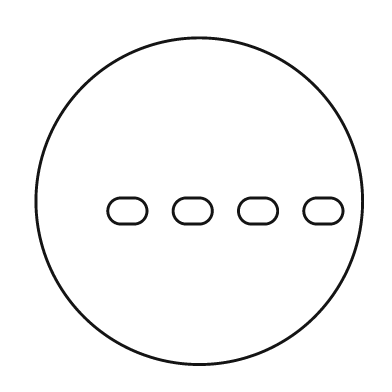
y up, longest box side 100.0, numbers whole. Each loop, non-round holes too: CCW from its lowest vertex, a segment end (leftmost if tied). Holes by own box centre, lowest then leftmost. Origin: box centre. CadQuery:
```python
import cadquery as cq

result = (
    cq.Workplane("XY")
    .moveTo(0.0, 0.0)
    .circle(50.0)
    .moveTo(-24.0, -7.0)
    .lineTo(-20.0, -7.0)
    .threePointArc((-16.0, -3.0), (-20.0, 1.0))
    .lineTo(-24.0, 1.0)
    .threePointArc((-28.0, -3.0), (-24.0, -7.0))
    .close()
    .moveTo(-4.0, -7.0)
    .lineTo(0.0, -7.0)
    .threePointArc((4.0, -3.0), (0.0, 1.0))
    .lineTo(-4.0, 1.0)
    .threePointArc((-8.0, -3.0), (-4.0, -7.0))
    .close()
    .moveTo(16.0, -7.0)
    .lineTo(20.0, -7.0)
    .threePointArc((24.0, -3.0), (20.0, 1.0))
    .lineTo(16.0, 1.0)
    .threePointArc((12.0, -3.0), (16.0, -7.0))
    .close()
    .moveTo(36.0, -7.0)
    .lineTo(40.0, -7.0)
    .threePointArc((44.0, -3.0), (40.0, 1.0))
    .lineTo(36.0, 1.0)
    .threePointArc((32.0, -3.0), (36.0, -7.0))
    .close()
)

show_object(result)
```